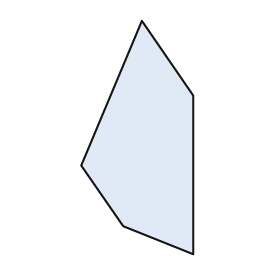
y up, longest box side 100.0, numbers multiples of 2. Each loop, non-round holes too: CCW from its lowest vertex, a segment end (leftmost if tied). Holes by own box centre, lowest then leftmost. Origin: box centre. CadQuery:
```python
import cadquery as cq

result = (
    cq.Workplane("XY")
    .moveTo(24.0, -50.0)
    .lineTo(24.0, 18.0)
    .lineTo(2.0, 50.0)
    .lineTo(-24.0, -12.0)
    .lineTo(-6.0, -38.0)
    .close()
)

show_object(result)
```